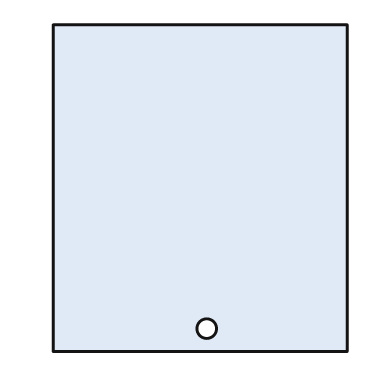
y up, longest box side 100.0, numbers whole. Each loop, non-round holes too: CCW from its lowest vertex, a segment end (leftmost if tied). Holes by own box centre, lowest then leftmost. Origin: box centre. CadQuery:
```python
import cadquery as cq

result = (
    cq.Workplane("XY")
    .moveTo(-45.0, -50.0)
    .lineTo(45.0, -50.0)
    .lineTo(45.0, 50.0)
    .lineTo(-45.0, 50.0)
    .close()
    .moveTo(2.0, -43.0)
    .circle(3.0)
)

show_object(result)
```